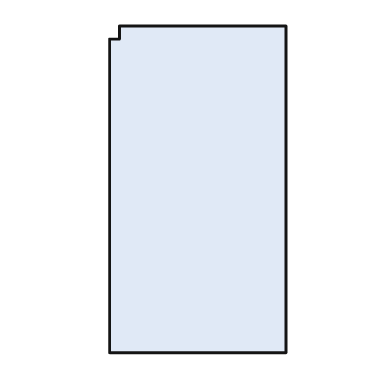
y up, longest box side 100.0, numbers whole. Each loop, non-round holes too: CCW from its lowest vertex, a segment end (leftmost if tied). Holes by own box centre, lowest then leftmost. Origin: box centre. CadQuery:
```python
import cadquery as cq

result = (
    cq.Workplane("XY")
    .moveTo(-27.0, -50.0)
    .lineTo(27.0, -50.0)
    .lineTo(27.0, 50.0)
    .lineTo(-24.0, 50.0)
    .lineTo(-24.0, 46.0)
    .lineTo(-27.0, 46.0)
    .close()
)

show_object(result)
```